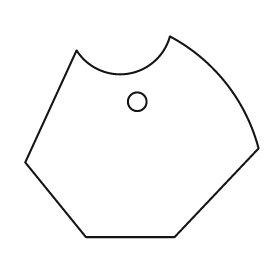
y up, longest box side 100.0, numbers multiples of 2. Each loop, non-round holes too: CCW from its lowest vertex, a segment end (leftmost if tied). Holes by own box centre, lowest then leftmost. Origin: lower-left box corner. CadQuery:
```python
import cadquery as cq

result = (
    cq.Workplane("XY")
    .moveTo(26.0, 0.0)
    .lineTo(64.0, 0.0)
    .lineTo(100.0, 38.0)
    .threePointArc((86.0, 66.0), (62.0, 86.0))
    .threePointArc((44.0, 70.0), (22.0, 80.0))
    .lineTo(0.0, 32.0)
    .close()
    .moveTo(48.0, 58.0)
    .circle(4.0)
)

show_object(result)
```